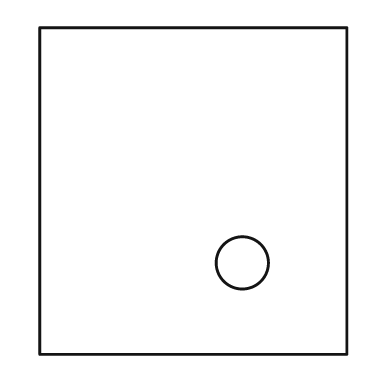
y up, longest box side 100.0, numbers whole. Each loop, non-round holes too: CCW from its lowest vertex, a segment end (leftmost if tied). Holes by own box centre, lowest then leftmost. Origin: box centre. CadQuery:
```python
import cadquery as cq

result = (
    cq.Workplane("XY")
    .moveTo(-47.0, -50.0)
    .lineTo(47.0, -50.0)
    .lineTo(47.0, 50.0)
    .lineTo(-47.0, 50.0)
    .close()
    .moveTo(15.0, -22.0)
    .circle(8.0)
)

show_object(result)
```